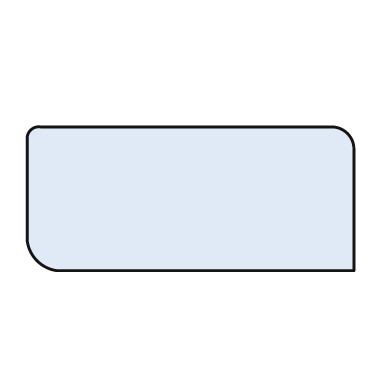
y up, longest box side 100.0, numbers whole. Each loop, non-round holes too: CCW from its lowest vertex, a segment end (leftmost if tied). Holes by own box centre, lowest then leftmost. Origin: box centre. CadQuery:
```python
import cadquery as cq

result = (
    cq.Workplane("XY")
    .moveTo(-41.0, -22.0)
    .lineTo(50.0, -22.0)
    .lineTo(50.0, 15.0)
    .threePointArc((48.0, 20.0), (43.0, 22.0))
    .lineTo(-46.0, 22.0)
    .threePointArc((-49.0, 21.0), (-50.0, 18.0))
    .lineTo(-50.0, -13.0)
    .threePointArc((-47.0, -19.0), (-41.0, -22.0))
    .close()
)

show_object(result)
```